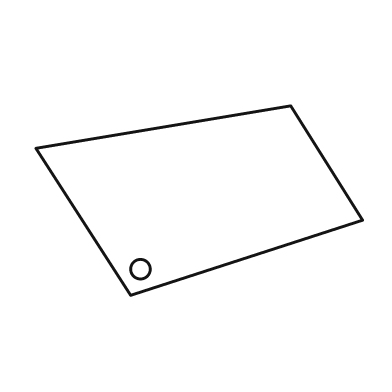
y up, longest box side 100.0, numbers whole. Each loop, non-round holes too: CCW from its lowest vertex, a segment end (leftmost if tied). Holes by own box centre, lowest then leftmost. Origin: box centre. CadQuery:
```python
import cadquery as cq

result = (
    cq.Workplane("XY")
    .moveTo(-21.0, -29.0)
    .lineTo(50.0, -6.0)
    .lineTo(28.0, 29.0)
    .lineTo(-50.0, 16.0)
    .close()
    .moveTo(-18.0, -21.0)
    .circle(3.0)
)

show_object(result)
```